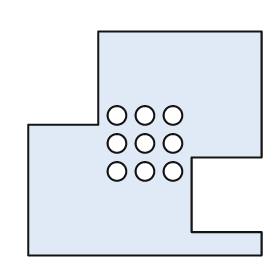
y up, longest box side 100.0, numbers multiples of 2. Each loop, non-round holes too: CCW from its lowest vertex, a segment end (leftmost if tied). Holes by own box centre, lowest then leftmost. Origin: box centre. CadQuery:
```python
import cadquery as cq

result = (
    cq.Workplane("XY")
    .moveTo(-50.0, -48.0)
    .lineTo(50.0, -48.0)
    .lineTo(50.0, -38.0)
    .lineTo(20.0, -38.0)
    .lineTo(20.0, -6.0)
    .lineTo(50.0, -6.0)
    .lineTo(50.0, 48.0)
    .lineTo(-20.0, 48.0)
    .lineTo(-20.0, 8.0)
    .lineTo(-50.0, 8.0)
    .close()
    .moveTo(-12.0, -12.0)
    .circle(4.0)
    .moveTo(0.0, -12.0)
    .circle(4.0)
    .moveTo(12.0, -12.0)
    .circle(4.0)
    .moveTo(-12.0, 0.0)
    .circle(4.0)
    .moveTo(0.0, 0.0)
    .circle(4.0)
    .moveTo(12.0, 0.0)
    .circle(4.0)
    .moveTo(-12.0, 12.0)
    .circle(4.0)
    .moveTo(0.0, 12.0)
    .circle(4.0)
    .moveTo(12.0, 12.0)
    .circle(4.0)
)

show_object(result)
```